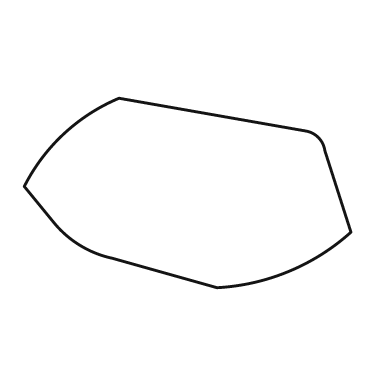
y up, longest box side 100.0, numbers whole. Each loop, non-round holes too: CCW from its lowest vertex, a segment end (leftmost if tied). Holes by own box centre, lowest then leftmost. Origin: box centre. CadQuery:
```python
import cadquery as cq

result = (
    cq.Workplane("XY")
    .moveTo(9.0, -29.0)
    .threePointArc((31.0, -24.0), (50.0, -12.0))
    .lineTo(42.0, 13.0)
    .threePointArc((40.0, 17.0), (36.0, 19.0))
    .lineTo(-21.0, 29.0)
    .threePointArc((-38.0, 18.0), (-50.0, 2.0))
    .lineTo(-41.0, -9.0)
    .threePointArc((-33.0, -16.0), (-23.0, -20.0))
    .close()
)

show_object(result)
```